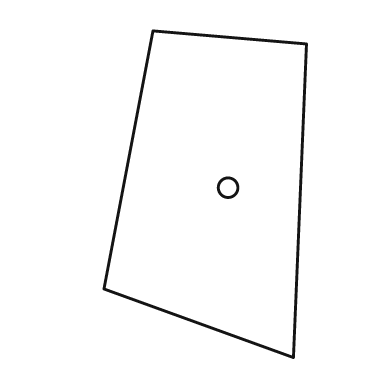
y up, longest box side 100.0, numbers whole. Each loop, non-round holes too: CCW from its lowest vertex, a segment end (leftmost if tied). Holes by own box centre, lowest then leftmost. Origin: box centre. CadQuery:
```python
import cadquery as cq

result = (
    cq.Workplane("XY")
    .moveTo(27.0, -50.0)
    .lineTo(31.0, 46.0)
    .lineTo(-16.0, 50.0)
    .lineTo(-31.0, -29.0)
    .close()
    .moveTo(7.0, 2.0)
    .circle(3.0)
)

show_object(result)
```